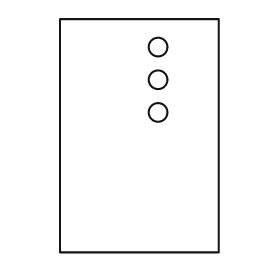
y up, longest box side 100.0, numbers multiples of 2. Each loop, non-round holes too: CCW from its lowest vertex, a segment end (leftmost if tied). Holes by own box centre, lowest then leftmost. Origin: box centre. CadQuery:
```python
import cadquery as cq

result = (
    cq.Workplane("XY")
    .moveTo(-34.0, -50.0)
    .lineTo(34.0, -50.0)
    .lineTo(34.0, 50.0)
    .lineTo(-34.0, 50.0)
    .close()
    .moveTo(8.0, 10.0)
    .circle(4.0)
    .moveTo(8.0, 24.0)
    .circle(4.0)
    .moveTo(8.0, 38.0)
    .circle(4.0)
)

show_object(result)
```